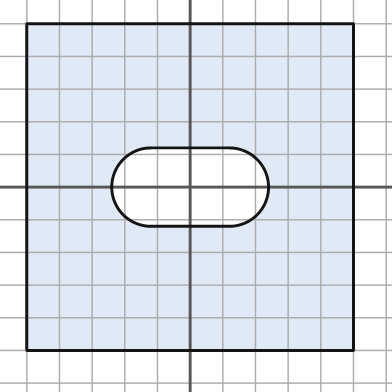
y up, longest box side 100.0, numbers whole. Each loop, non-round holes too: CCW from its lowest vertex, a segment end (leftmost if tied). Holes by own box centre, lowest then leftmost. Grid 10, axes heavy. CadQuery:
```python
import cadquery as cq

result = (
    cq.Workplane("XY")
    .moveTo(-50.0, -50.0)
    .lineTo(50.0, -50.0)
    .lineTo(50.0, 50.0)
    .lineTo(-50.0, 50.0)
    .close()
    .moveTo(-12.0, -12.0)
    .lineTo(12.0, -12.0)
    .threePointArc((24.0, 0.0), (12.0, 12.0))
    .lineTo(-12.0, 12.0)
    .threePointArc((-24.0, 0.0), (-12.0, -12.0))
    .close()
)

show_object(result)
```